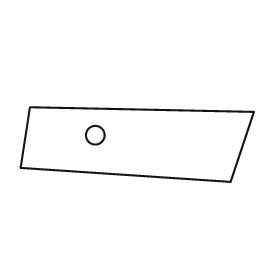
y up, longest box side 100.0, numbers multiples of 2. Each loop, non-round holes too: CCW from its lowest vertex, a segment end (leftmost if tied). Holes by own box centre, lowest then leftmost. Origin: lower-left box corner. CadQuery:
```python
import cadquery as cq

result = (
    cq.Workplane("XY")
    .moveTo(90.0, 0.0)
    .lineTo(100.0, 30.0)
    .lineTo(4.0, 32.0)
    .lineTo(0.0, 6.0)
    .close()
    .moveTo(32.0, 20.0)
    .circle(4.0)
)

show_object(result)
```